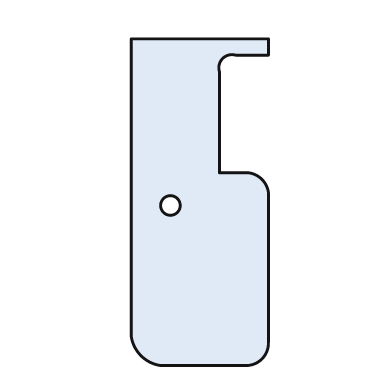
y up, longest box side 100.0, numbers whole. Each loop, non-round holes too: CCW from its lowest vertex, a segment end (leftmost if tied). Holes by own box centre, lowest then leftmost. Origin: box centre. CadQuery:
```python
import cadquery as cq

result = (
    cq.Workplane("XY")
    .moveTo(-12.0, -50.0)
    .lineTo(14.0, -50.0)
    .threePointArc((19.0, -48.0), (21.0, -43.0))
    .lineTo(21.0, 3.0)
    .threePointArc((19.0, 7.0), (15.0, 9.0))
    .lineTo(6.0, 9.0)
    .lineTo(6.0, 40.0)
    .threePointArc((7.0, 44.0), (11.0, 45.0))
    .lineTo(21.0, 45.0)
    .lineTo(21.0, 50.0)
    .lineTo(-21.0, 50.0)
    .lineTo(-21.0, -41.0)
    .threePointArc((-18.0, -47.0), (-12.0, -50.0))
    .close()
    .moveTo(-9.0, -1.0)
    .circle(3.0)
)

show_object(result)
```